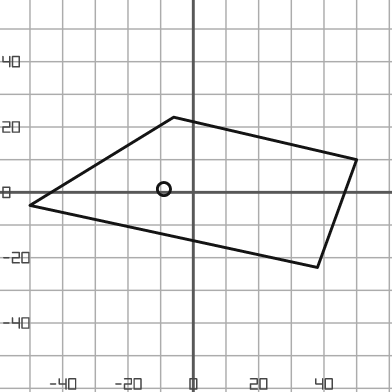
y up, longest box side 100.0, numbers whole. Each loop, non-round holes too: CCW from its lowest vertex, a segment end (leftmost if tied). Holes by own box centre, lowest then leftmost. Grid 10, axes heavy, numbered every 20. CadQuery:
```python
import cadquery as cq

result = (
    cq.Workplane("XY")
    .moveTo(38.0, -23.0)
    .lineTo(50.0, 10.0)
    .lineTo(-6.0, 23.0)
    .lineTo(-50.0, -4.0)
    .close()
    .moveTo(-9.0, 1.0)
    .circle(2.0)
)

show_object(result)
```